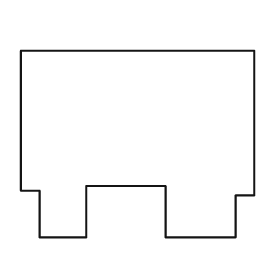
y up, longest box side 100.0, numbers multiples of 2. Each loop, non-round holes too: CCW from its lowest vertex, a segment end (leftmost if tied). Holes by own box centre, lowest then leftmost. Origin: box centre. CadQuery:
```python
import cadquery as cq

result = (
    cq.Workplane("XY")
    .moveTo(-42.0, -40.0)
    .lineTo(-22.0, -40.0)
    .lineTo(-22.0, -18.0)
    .lineTo(12.0, -18.0)
    .lineTo(12.0, -40.0)
    .lineTo(42.0, -40.0)
    .lineTo(42.0, -22.0)
    .lineTo(50.0, -22.0)
    .lineTo(50.0, 40.0)
    .lineTo(-50.0, 40.0)
    .lineTo(-50.0, -20.0)
    .lineTo(-42.0, -20.0)
    .close()
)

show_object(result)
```